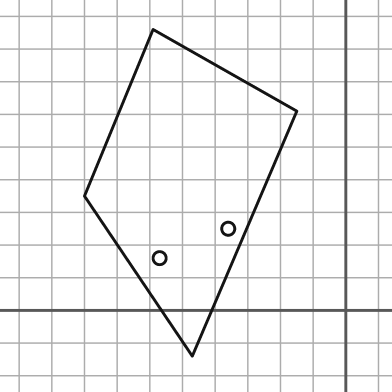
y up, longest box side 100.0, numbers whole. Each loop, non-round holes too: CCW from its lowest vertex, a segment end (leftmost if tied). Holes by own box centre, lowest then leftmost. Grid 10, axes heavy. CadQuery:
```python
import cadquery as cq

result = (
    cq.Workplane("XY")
    .moveTo(-47.0, -14.0)
    .lineTo(-15.0, 61.0)
    .lineTo(-59.0, 86.0)
    .lineTo(-80.0, 35.0)
    .close()
    .moveTo(-57.0, 16.0)
    .circle(2.0)
    .moveTo(-36.0, 25.0)
    .circle(2.0)
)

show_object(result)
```